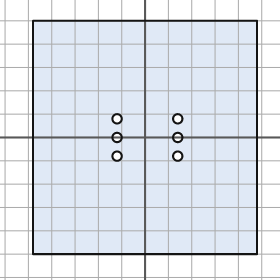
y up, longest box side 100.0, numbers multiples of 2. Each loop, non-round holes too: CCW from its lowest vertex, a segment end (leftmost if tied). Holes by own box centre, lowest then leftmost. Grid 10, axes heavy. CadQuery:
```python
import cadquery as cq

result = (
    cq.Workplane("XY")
    .moveTo(-48.0, -50.0)
    .lineTo(48.0, -50.0)
    .lineTo(48.0, 50.0)
    .lineTo(-48.0, 50.0)
    .close()
    .moveTo(-12.0, -8.0)
    .circle(2.0)
    .moveTo(14.0, -8.0)
    .circle(2.0)
    .moveTo(-12.0, 0.0)
    .circle(2.0)
    .moveTo(14.0, 0.0)
    .circle(2.0)
    .moveTo(-12.0, 8.0)
    .circle(2.0)
    .moveTo(14.0, 8.0)
    .circle(2.0)
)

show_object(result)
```